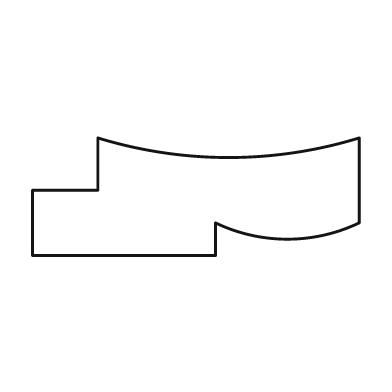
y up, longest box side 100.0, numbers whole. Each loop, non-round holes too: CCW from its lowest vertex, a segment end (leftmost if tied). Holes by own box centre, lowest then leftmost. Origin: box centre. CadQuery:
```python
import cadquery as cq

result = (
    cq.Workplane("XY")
    .moveTo(-50.0, -18.0)
    .lineTo(6.0, -18.0)
    .lineTo(6.0, -8.0)
    .threePointArc((28.0, -13.0), (50.0, -8.0))
    .lineTo(50.0, 18.0)
    .threePointArc((10.0, 12.0), (-30.0, 18.0))
    .lineTo(-30.0, 2.0)
    .lineTo(-50.0, 2.0)
    .close()
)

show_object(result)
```